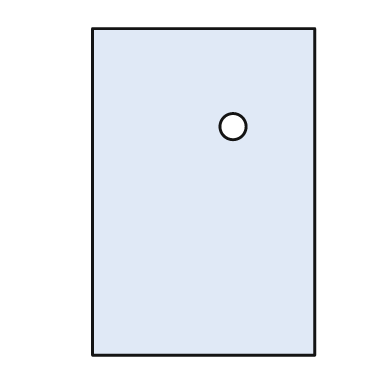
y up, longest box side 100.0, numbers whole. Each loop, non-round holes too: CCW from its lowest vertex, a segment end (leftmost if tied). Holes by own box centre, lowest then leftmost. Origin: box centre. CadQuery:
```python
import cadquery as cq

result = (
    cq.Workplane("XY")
    .moveTo(-34.0, -50.0)
    .lineTo(34.0, -50.0)
    .lineTo(34.0, 50.0)
    .lineTo(-34.0, 50.0)
    .close()
    .moveTo(9.0, 20.0)
    .circle(4.0)
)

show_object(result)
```